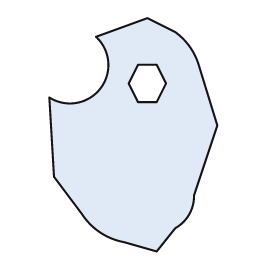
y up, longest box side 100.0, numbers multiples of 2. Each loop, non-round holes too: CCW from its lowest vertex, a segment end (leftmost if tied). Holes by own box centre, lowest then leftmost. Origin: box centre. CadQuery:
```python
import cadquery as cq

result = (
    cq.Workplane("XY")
    .moveTo(10.0, -50.0)
    .lineTo(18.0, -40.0)
    .threePointArc((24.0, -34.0), (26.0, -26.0))
    .lineTo(36.0, 4.0)
    .lineTo(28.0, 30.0)
    .threePointArc((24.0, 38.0), (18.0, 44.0))
    .lineTo(6.0, 50.0)
    .lineTo(-16.0, 42.0)
    .threePointArc((-14.0, 20.0), (-36.0, 16.0))
    .lineTo(-34.0, -18.0)
    .lineTo(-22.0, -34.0)
    .threePointArc((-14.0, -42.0), (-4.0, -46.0))
    .close()
    .moveTo(2.0, 14.0)
    .lineTo(10.0, 14.0)
    .lineTo(14.0, 22.0)
    .lineTo(10.0, 30.0)
    .lineTo(2.0, 30.0)
    .lineTo(-2.0, 22.0)
    .close()
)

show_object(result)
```